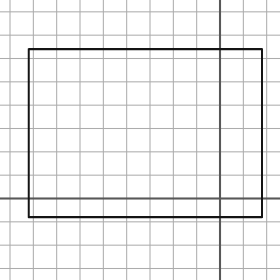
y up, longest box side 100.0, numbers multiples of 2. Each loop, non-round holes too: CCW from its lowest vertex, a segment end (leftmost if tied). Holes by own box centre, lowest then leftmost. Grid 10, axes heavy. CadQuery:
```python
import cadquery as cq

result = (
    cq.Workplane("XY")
    .moveTo(-82.0, -8.0)
    .lineTo(18.0, -8.0)
    .lineTo(18.0, 64.0)
    .lineTo(-82.0, 64.0)
    .close()
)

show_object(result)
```